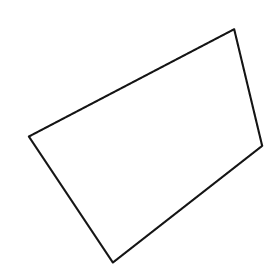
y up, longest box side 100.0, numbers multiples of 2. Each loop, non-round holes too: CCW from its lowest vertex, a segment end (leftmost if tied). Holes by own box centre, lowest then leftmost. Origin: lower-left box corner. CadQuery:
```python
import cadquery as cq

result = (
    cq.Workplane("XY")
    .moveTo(36.0, 0.0)
    .lineTo(100.0, 50.0)
    .lineTo(88.0, 100.0)
    .lineTo(0.0, 54.0)
    .close()
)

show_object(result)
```